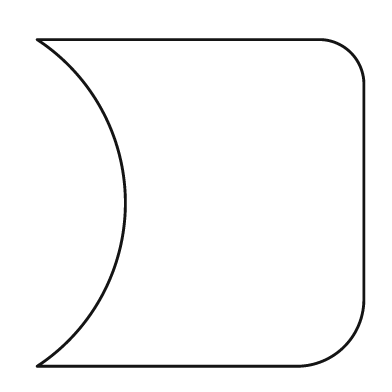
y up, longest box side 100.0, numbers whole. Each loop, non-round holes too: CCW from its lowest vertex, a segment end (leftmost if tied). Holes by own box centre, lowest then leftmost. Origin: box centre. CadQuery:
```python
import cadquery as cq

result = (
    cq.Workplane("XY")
    .moveTo(-50.0, -50.0)
    .lineTo(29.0, -50.0)
    .threePointArc((44.0, -44.0), (50.0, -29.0))
    .lineTo(50.0, 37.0)
    .threePointArc((46.0, 46.0), (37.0, 50.0))
    .lineTo(-50.0, 50.0)
    .threePointArc((-23.0, 0.0), (-50.0, -50.0))
    .close()
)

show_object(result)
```